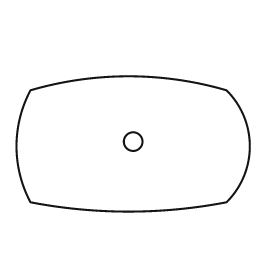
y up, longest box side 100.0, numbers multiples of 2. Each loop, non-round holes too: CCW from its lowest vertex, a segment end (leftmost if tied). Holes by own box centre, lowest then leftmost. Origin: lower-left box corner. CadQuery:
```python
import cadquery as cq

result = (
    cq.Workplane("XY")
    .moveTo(6.0, 4.0)
    .threePointArc((48.0, 0.0), (90.0, 4.0))
    .threePointArc((100.0, 28.0), (90.0, 52.0))
    .threePointArc((48.0, 58.0), (6.0, 52.0))
    .threePointArc((0.0, 28.0), (6.0, 4.0))
    .close()
    .moveTo(50.0, 30.0)
    .circle(4.0)
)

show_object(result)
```